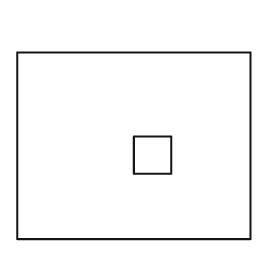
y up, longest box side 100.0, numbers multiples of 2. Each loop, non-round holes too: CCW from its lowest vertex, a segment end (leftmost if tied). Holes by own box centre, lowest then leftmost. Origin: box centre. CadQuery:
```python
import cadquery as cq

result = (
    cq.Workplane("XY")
    .moveTo(-50.0, -40.0)
    .lineTo(50.0, -40.0)
    .lineTo(50.0, 40.0)
    .lineTo(-50.0, 40.0)
    .close()
    .moveTo(0.0, -12.0)
    .lineTo(16.0, -12.0)
    .lineTo(16.0, 4.0)
    .lineTo(0.0, 4.0)
    .close()
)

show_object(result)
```